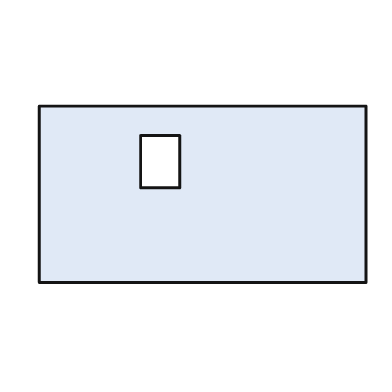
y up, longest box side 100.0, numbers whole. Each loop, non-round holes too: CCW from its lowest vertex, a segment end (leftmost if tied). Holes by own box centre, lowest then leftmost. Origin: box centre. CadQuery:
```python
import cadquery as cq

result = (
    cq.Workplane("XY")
    .moveTo(-50.0, -27.0)
    .lineTo(50.0, -27.0)
    .lineTo(50.0, 27.0)
    .lineTo(-50.0, 27.0)
    .close()
    .moveTo(-19.0, 2.0)
    .lineTo(-7.0, 2.0)
    .lineTo(-7.0, 18.0)
    .lineTo(-19.0, 18.0)
    .close()
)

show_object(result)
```